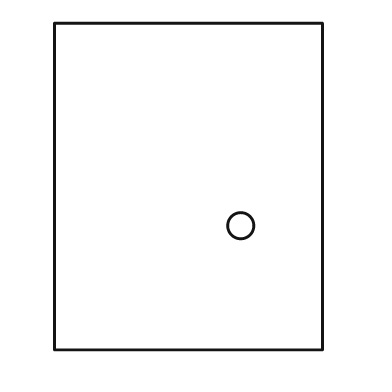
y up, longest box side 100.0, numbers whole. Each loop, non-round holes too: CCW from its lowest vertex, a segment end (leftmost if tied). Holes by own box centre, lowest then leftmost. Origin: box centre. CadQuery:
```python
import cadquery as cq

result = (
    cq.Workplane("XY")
    .moveTo(-41.0, -50.0)
    .lineTo(41.0, -50.0)
    .lineTo(41.0, 50.0)
    .lineTo(-41.0, 50.0)
    .close()
    .moveTo(16.0, -12.0)
    .circle(4.0)
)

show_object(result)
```